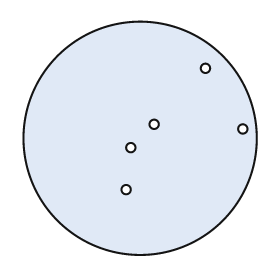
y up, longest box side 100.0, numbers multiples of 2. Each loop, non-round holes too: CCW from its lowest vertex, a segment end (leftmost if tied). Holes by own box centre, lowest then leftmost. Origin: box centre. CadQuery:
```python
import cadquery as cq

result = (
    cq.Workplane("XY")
    .moveTo(0.0, 0.0)
    .circle(50.0)
    .moveTo(-6.0, -22.0)
    .circle(2.0)
    .moveTo(-4.0, -4.0)
    .circle(2.0)
    .moveTo(44.0, 4.0)
    .circle(2.0)
    .moveTo(6.0, 6.0)
    .circle(2.0)
    .moveTo(28.0, 30.0)
    .circle(2.0)
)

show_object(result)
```